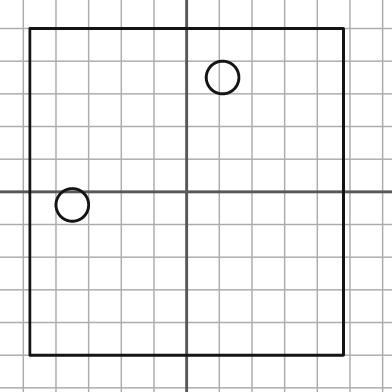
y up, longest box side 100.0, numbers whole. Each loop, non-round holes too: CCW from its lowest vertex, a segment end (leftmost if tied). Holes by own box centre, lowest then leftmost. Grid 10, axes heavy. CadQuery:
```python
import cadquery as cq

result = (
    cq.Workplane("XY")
    .moveTo(-48.0, -50.0)
    .lineTo(48.0, -50.0)
    .lineTo(48.0, 50.0)
    .lineTo(-48.0, 50.0)
    .close()
    .moveTo(-35.0, -4.0)
    .circle(5.0)
    .moveTo(11.0, 35.0)
    .circle(5.0)
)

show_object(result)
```